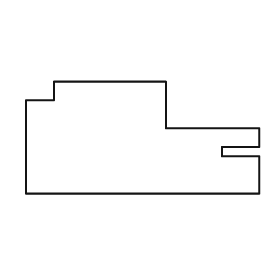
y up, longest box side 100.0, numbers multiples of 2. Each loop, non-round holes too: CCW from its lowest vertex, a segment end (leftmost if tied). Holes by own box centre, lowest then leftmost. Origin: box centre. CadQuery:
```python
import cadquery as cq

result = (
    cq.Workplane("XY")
    .moveTo(-50.0, -24.0)
    .lineTo(50.0, -24.0)
    .lineTo(50.0, -8.0)
    .lineTo(34.0, -8.0)
    .lineTo(34.0, -4.0)
    .lineTo(50.0, -4.0)
    .lineTo(50.0, 4.0)
    .lineTo(10.0, 4.0)
    .lineTo(10.0, 24.0)
    .lineTo(-38.0, 24.0)
    .lineTo(-38.0, 16.0)
    .lineTo(-50.0, 16.0)
    .close()
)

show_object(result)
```